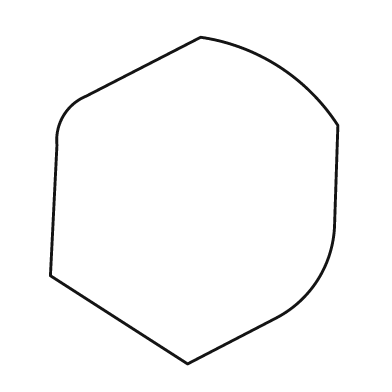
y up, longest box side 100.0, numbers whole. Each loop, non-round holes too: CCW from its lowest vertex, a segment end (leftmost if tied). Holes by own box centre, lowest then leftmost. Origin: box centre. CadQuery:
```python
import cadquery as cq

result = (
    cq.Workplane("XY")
    .moveTo(-2.0, -50.0)
    .lineTo(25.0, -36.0)
    .threePointArc((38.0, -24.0), (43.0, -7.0))
    .lineTo(44.0, 23.0)
    .threePointArc((26.0, 41.0), (2.0, 50.0))
    .lineTo(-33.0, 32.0)
    .threePointArc((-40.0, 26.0), (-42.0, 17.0))
    .lineTo(-44.0, -23.0)
    .close()
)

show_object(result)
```